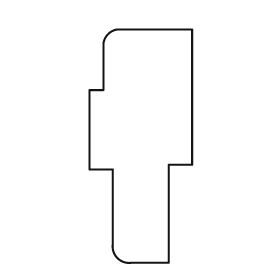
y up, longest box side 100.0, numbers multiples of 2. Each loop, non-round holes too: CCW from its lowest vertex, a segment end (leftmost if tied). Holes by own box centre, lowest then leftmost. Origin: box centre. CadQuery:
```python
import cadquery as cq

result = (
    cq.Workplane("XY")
    .moveTo(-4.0, -50.0)
    .lineTo(12.0, -50.0)
    .lineTo(12.0, -8.0)
    .lineTo(22.0, -8.0)
    .lineTo(22.0, 50.0)
    .lineTo(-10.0, 50.0)
    .threePointArc((-14.0, 48.0), (-16.0, 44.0))
    .lineTo(-16.0, 24.0)
    .lineTo(-22.0, 24.0)
    .lineTo(-22.0, -10.0)
    .lineTo(-12.0, -10.0)
    .lineTo(-12.0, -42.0)
    .threePointArc((-10.0, -48.0), (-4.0, -50.0))
    .close()
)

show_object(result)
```